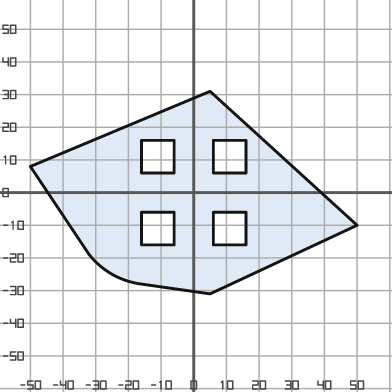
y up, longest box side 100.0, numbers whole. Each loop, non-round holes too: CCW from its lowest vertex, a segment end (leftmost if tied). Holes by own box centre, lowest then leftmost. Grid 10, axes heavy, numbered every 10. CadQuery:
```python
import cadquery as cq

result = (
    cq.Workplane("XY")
    .moveTo(5.0, -31.0)
    .lineTo(50.0, -10.0)
    .lineTo(5.0, 31.0)
    .lineTo(-50.0, 8.0)
    .lineTo(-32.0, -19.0)
    .threePointArc((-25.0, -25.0), (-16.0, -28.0))
    .close()
    .moveTo(-16.0, -16.0)
    .lineTo(-6.0, -16.0)
    .lineTo(-6.0, -6.0)
    .lineTo(-16.0, -6.0)
    .close()
    .moveTo(6.0, -16.0)
    .lineTo(16.0, -16.0)
    .lineTo(16.0, -6.0)
    .lineTo(6.0, -6.0)
    .close()
    .moveTo(-16.0, 6.0)
    .lineTo(-6.0, 6.0)
    .lineTo(-6.0, 16.0)
    .lineTo(-16.0, 16.0)
    .close()
    .moveTo(6.0, 6.0)
    .lineTo(16.0, 6.0)
    .lineTo(16.0, 16.0)
    .lineTo(6.0, 16.0)
    .close()
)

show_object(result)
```